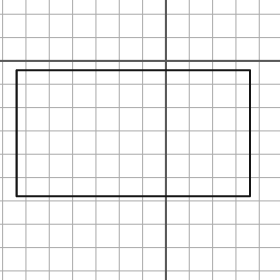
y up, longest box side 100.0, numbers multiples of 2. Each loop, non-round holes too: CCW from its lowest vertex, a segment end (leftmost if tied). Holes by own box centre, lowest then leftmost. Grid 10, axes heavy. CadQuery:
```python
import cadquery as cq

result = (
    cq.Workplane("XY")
    .moveTo(-64.0, -58.0)
    .lineTo(36.0, -58.0)
    .lineTo(36.0, -4.0)
    .lineTo(-64.0, -4.0)
    .close()
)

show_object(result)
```